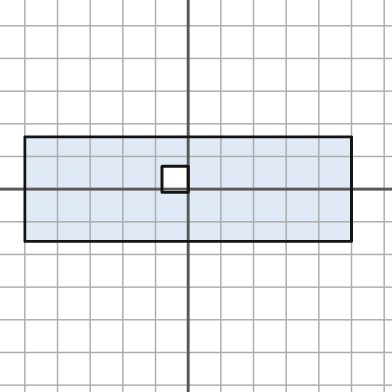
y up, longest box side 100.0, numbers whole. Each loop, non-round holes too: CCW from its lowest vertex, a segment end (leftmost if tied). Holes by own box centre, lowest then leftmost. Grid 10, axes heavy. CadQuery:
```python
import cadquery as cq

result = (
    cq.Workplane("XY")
    .moveTo(-50.0, -16.0)
    .lineTo(50.0, -16.0)
    .lineTo(50.0, 16.0)
    .lineTo(-50.0, 16.0)
    .close()
    .moveTo(-8.0, -1.0)
    .lineTo(0.0, -1.0)
    .lineTo(0.0, 7.0)
    .lineTo(-8.0, 7.0)
    .close()
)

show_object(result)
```